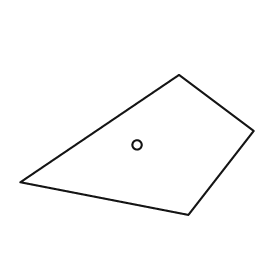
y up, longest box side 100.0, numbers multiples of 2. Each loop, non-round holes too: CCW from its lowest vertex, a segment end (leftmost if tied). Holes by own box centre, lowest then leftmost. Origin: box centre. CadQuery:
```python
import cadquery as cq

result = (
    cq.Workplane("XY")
    .moveTo(22.0, -30.0)
    .lineTo(50.0, 6.0)
    .lineTo(18.0, 30.0)
    .lineTo(-50.0, -16.0)
    .close()
    .moveTo(0.0, 0.0)
    .circle(2.0)
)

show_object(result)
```